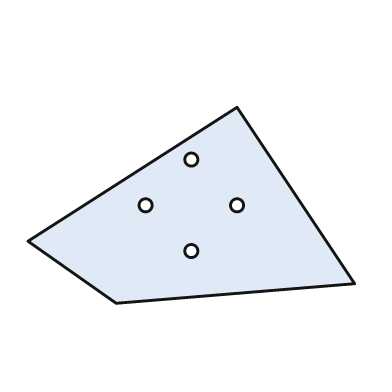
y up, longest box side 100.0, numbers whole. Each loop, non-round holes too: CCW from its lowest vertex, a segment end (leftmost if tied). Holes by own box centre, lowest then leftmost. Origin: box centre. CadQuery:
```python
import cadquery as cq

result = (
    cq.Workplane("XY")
    .moveTo(-23.0, -30.0)
    .lineTo(50.0, -24.0)
    .lineTo(14.0, 30.0)
    .lineTo(-50.0, -11.0)
    .close()
    .moveTo(0.0, -14.0)
    .circle(2.0)
    .moveTo(-14.0, 0.0)
    .circle(2.0)
    .moveTo(14.0, 0.0)
    .circle(2.0)
    .moveTo(0.0, 14.0)
    .circle(2.0)
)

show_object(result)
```